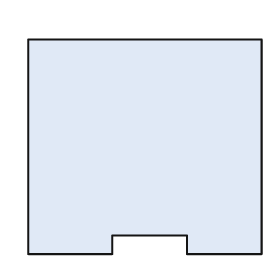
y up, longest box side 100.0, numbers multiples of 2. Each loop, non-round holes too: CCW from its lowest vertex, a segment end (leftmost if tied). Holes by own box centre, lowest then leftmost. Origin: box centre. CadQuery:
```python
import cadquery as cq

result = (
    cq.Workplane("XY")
    .moveTo(-50.0, -46.0)
    .lineTo(-14.0, -46.0)
    .lineTo(-14.0, -38.0)
    .lineTo(18.0, -38.0)
    .lineTo(18.0, -46.0)
    .lineTo(50.0, -46.0)
    .lineTo(50.0, 46.0)
    .lineTo(-50.0, 46.0)
    .close()
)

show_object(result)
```